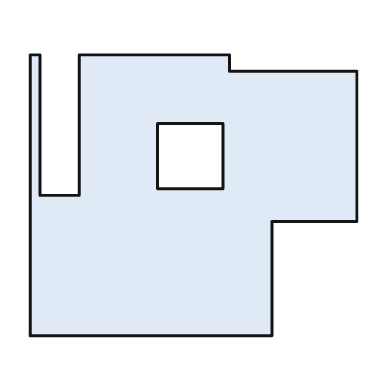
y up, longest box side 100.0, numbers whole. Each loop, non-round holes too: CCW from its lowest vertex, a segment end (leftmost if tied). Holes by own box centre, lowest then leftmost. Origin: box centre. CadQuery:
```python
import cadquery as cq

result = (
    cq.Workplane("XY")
    .moveTo(-50.0, -43.0)
    .lineTo(24.0, -43.0)
    .lineTo(24.0, -8.0)
    .lineTo(50.0, -8.0)
    .lineTo(50.0, 38.0)
    .lineTo(11.0, 38.0)
    .lineTo(11.0, 43.0)
    .lineTo(-35.0, 43.0)
    .lineTo(-35.0, 0.0)
    .lineTo(-47.0, 0.0)
    .lineTo(-47.0, 43.0)
    .lineTo(-50.0, 43.0)
    .close()
    .moveTo(-11.0, 2.0)
    .lineTo(9.0, 2.0)
    .lineTo(9.0, 22.0)
    .lineTo(-11.0, 22.0)
    .close()
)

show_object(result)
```